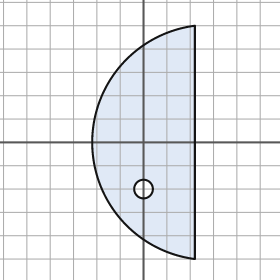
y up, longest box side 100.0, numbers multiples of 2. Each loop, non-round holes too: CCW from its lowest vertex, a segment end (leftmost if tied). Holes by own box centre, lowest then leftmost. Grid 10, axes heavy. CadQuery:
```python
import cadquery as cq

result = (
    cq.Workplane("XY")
    .moveTo(22.0, -50.0)
    .lineTo(22.0, 50.0)
    .threePointArc((-22.0, 0.0), (22.0, -50.0))
    .close()
    .moveTo(0.0, -20.0)
    .circle(4.0)
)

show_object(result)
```